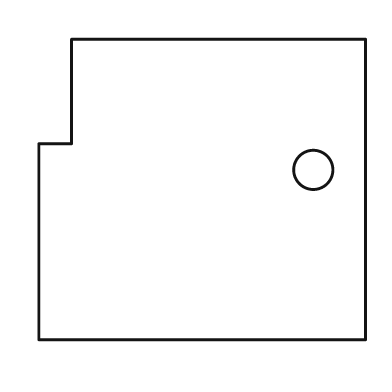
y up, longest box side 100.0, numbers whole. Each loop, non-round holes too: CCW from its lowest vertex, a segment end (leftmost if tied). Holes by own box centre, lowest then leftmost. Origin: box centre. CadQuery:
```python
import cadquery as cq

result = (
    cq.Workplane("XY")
    .moveTo(-50.0, -46.0)
    .lineTo(50.0, -46.0)
    .lineTo(50.0, 46.0)
    .lineTo(-40.0, 46.0)
    .lineTo(-40.0, 14.0)
    .lineTo(-50.0, 14.0)
    .close()
    .moveTo(34.0, 6.0)
    .circle(6.0)
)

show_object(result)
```